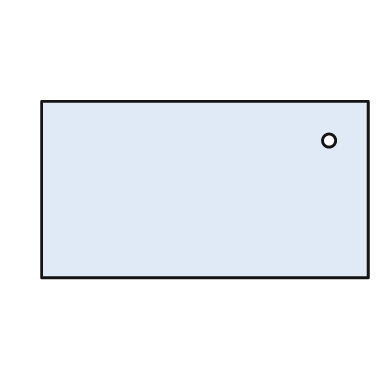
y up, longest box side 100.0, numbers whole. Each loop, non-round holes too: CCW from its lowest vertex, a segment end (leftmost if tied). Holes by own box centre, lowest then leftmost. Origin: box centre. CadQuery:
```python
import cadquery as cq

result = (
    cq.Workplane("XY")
    .moveTo(-50.0, -27.0)
    .lineTo(50.0, -27.0)
    .lineTo(50.0, 27.0)
    .lineTo(-50.0, 27.0)
    .close()
    .moveTo(38.0, 15.0)
    .circle(2.0)
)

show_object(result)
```